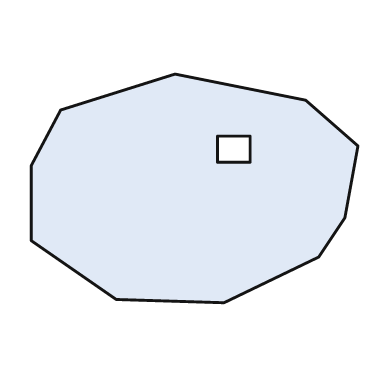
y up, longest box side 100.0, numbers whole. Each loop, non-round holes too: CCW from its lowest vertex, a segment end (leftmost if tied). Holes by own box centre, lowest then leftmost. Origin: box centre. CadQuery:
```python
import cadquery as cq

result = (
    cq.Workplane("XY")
    .moveTo(9.0, -35.0)
    .lineTo(38.0, -21.0)
    .lineTo(46.0, -9.0)
    .lineTo(50.0, 13.0)
    .lineTo(34.0, 27.0)
    .lineTo(-6.0, 35.0)
    .lineTo(-41.0, 24.0)
    .lineTo(-50.0, 7.0)
    .lineTo(-50.0, -16.0)
    .lineTo(-24.0, -34.0)
    .close()
    .moveTo(7.0, 8.0)
    .lineTo(17.0, 8.0)
    .lineTo(17.0, 16.0)
    .lineTo(7.0, 16.0)
    .close()
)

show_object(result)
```